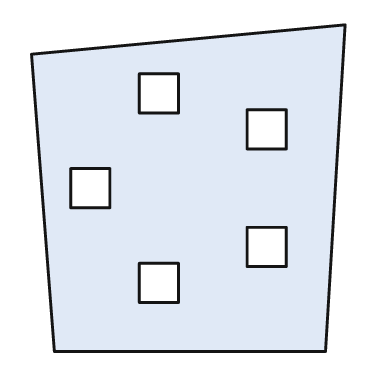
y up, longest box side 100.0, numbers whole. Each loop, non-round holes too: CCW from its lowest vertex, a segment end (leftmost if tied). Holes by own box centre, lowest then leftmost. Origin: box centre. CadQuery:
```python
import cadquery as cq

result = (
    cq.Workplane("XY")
    .moveTo(-41.0, -50.0)
    .lineTo(42.0, -50.0)
    .lineTo(48.0, 50.0)
    .lineTo(-48.0, 41.0)
    .close()
    .moveTo(-15.0, -35.0)
    .lineTo(-3.0, -35.0)
    .lineTo(-3.0, -23.0)
    .lineTo(-15.0, -23.0)
    .close()
    .moveTo(18.0, -24.0)
    .lineTo(30.0, -24.0)
    .lineTo(30.0, -12.0)
    .lineTo(18.0, -12.0)
    .close()
    .moveTo(-36.0, -6.0)
    .lineTo(-24.0, -6.0)
    .lineTo(-24.0, 6.0)
    .lineTo(-36.0, 6.0)
    .close()
    .moveTo(18.0, 12.0)
    .lineTo(30.0, 12.0)
    .lineTo(30.0, 24.0)
    .lineTo(18.0, 24.0)
    .close()
    .moveTo(-15.0, 23.0)
    .lineTo(-3.0, 23.0)
    .lineTo(-3.0, 35.0)
    .lineTo(-15.0, 35.0)
    .close()
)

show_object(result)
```